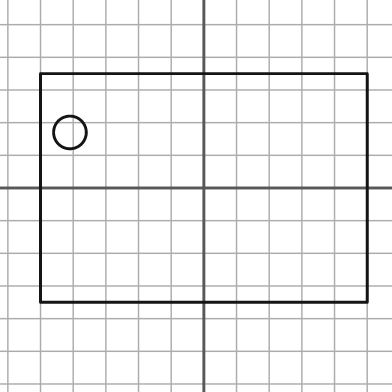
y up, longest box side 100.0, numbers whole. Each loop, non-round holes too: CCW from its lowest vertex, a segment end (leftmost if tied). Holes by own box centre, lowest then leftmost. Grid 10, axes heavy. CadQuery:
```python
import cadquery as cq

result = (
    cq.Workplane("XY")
    .moveTo(-50.0, -35.0)
    .lineTo(50.0, -35.0)
    .lineTo(50.0, 35.0)
    .lineTo(-50.0, 35.0)
    .close()
    .moveTo(-41.0, 17.0)
    .circle(5.0)
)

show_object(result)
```